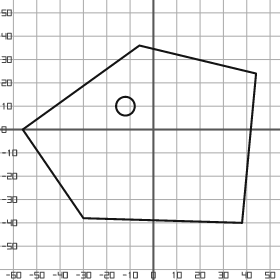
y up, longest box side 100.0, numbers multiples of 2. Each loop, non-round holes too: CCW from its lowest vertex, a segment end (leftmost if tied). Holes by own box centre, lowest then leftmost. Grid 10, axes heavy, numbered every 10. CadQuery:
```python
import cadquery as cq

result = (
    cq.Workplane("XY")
    .moveTo(38.0, -40.0)
    .lineTo(44.0, 24.0)
    .lineTo(-6.0, 36.0)
    .lineTo(-56.0, 0.0)
    .lineTo(-30.0, -38.0)
    .close()
    .moveTo(-12.0, 10.0)
    .circle(4.0)
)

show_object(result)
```